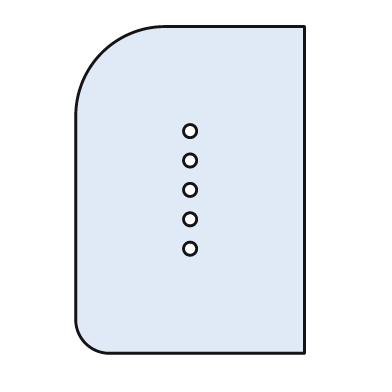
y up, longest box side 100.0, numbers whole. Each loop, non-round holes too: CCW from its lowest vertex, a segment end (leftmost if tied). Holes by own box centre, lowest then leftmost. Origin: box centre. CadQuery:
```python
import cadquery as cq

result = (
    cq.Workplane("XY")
    .moveTo(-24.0, -50.0)
    .lineTo(35.0, -50.0)
    .lineTo(35.0, 50.0)
    .lineTo(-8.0, 50.0)
    .threePointArc((-27.0, 42.0), (-35.0, 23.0))
    .lineTo(-35.0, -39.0)
    .threePointArc((-32.0, -47.0), (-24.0, -50.0))
    .close()
    .moveTo(0.0, -18.0)
    .circle(2.0)
    .moveTo(0.0, -9.0)
    .circle(2.0)
    .moveTo(0.0, 0.0)
    .circle(2.0)
    .moveTo(0.0, 9.0)
    .circle(2.0)
    .moveTo(0.0, 18.0)
    .circle(2.0)
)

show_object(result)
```